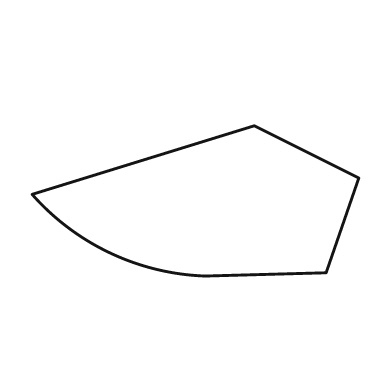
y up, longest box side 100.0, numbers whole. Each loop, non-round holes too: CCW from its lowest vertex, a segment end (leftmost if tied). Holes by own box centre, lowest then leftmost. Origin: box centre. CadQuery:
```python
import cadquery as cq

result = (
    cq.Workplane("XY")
    .moveTo(3.0, -23.0)
    .lineTo(40.0, -22.0)
    .lineTo(50.0, 7.0)
    .lineTo(18.0, 23.0)
    .lineTo(-50.0, 2.0)
    .threePointArc((-26.0, -16.0), (3.0, -23.0))
    .close()
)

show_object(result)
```